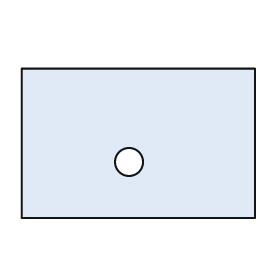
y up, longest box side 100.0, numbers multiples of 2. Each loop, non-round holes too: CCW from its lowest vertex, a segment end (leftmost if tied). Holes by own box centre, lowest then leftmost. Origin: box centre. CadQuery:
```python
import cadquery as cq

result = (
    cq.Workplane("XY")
    .moveTo(-50.0, -32.0)
    .lineTo(50.0, -32.0)
    .lineTo(50.0, 32.0)
    .lineTo(-50.0, 32.0)
    .close()
    .moveTo(-4.0, -8.0)
    .circle(6.0)
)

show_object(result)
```